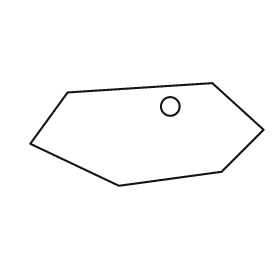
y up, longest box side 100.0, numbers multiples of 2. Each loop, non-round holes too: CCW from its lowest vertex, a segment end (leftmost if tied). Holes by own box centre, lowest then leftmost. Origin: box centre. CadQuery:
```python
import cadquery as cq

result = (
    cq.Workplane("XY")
    .moveTo(-12.0, -22.0)
    .lineTo(32.0, -16.0)
    .lineTo(50.0, 2.0)
    .lineTo(28.0, 22.0)
    .lineTo(-34.0, 18.0)
    .lineTo(-50.0, -4.0)
    .close()
    .moveTo(10.0, 12.0)
    .circle(4.0)
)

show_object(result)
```